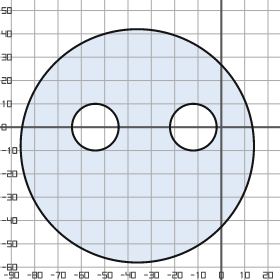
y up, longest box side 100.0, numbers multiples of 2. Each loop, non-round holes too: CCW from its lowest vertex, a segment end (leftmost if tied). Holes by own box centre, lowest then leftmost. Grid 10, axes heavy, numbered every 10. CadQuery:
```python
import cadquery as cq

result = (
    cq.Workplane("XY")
    .moveTo(-36.0, -8.0)
    .circle(50.0)
    .moveTo(-54.0, 0.0)
    .circle(10.0)
    .moveTo(-12.0, 0.0)
    .circle(10.0)
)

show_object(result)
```